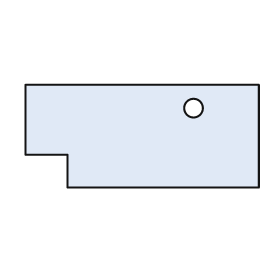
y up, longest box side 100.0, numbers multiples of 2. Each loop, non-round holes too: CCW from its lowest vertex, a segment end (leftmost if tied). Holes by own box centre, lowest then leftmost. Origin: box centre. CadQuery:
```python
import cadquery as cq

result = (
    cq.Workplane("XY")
    .moveTo(-32.0, -22.0)
    .lineTo(50.0, -22.0)
    .lineTo(50.0, 22.0)
    .lineTo(-50.0, 22.0)
    .lineTo(-50.0, -8.0)
    .lineTo(-32.0, -8.0)
    .close()
    .moveTo(22.0, 12.0)
    .circle(4.0)
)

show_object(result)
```